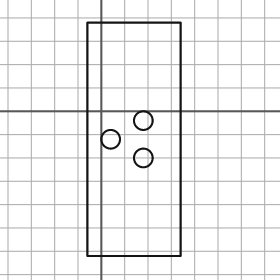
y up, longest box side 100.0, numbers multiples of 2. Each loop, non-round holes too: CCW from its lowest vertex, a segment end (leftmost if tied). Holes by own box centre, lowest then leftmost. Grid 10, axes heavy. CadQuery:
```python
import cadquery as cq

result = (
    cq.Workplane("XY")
    .moveTo(-6.0, -62.0)
    .lineTo(34.0, -62.0)
    .lineTo(34.0, 38.0)
    .lineTo(-6.0, 38.0)
    .close()
    .moveTo(18.0, -20.0)
    .circle(4.0)
    .moveTo(4.0, -12.0)
    .circle(4.0)
    .moveTo(18.0, -4.0)
    .circle(4.0)
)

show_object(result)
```